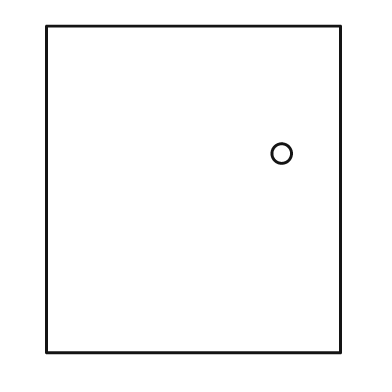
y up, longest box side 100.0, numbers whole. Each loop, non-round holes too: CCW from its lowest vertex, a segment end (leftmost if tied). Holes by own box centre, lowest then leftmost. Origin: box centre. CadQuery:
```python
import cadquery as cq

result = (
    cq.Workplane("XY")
    .moveTo(-45.0, -50.0)
    .lineTo(45.0, -50.0)
    .lineTo(45.0, 50.0)
    .lineTo(-45.0, 50.0)
    .close()
    .moveTo(27.0, 11.0)
    .circle(3.0)
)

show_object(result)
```